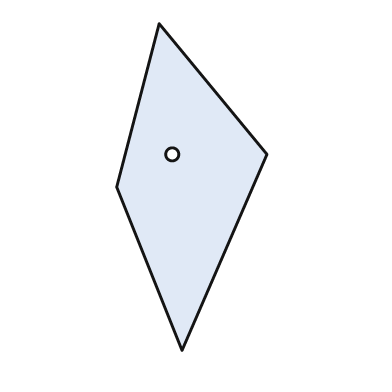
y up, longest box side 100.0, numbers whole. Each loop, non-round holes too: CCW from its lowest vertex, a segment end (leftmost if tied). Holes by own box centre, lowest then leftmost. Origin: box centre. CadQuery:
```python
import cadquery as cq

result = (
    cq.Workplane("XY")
    .moveTo(-3.0, -50.0)
    .lineTo(23.0, 10.0)
    .lineTo(-10.0, 50.0)
    .lineTo(-23.0, 0.0)
    .close()
    .moveTo(-6.0, 10.0)
    .circle(2.0)
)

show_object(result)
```